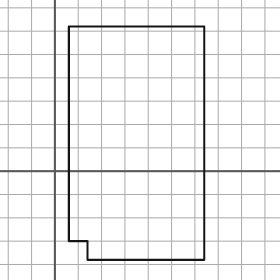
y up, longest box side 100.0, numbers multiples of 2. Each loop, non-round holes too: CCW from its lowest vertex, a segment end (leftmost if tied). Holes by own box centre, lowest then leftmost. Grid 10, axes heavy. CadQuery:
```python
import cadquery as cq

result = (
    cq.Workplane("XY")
    .moveTo(14.0, -38.0)
    .lineTo(64.0, -38.0)
    .lineTo(64.0, 62.0)
    .lineTo(6.0, 62.0)
    .lineTo(6.0, -30.0)
    .lineTo(14.0, -30.0)
    .close()
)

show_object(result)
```